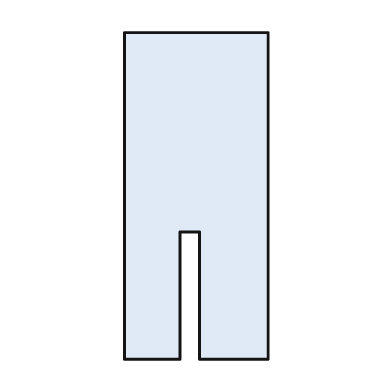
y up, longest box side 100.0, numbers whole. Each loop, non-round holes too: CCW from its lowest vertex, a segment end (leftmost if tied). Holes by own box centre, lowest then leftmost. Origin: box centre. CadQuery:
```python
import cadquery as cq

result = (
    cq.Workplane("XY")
    .moveTo(-22.0, -50.0)
    .lineTo(-5.0, -50.0)
    .lineTo(-5.0, -11.0)
    .lineTo(1.0, -11.0)
    .lineTo(1.0, -50.0)
    .lineTo(22.0, -50.0)
    .lineTo(22.0, 50.0)
    .lineTo(-22.0, 50.0)
    .close()
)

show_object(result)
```